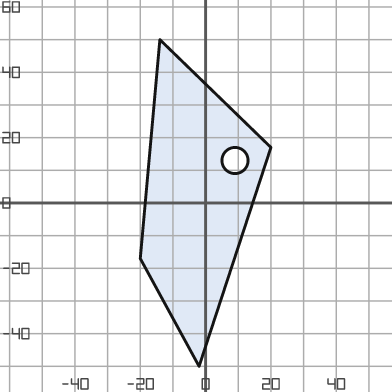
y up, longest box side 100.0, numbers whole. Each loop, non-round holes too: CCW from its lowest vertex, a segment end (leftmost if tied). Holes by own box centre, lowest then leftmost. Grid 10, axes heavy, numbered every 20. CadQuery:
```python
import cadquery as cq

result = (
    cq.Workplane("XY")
    .moveTo(-2.0, -50.0)
    .lineTo(20.0, 17.0)
    .lineTo(-14.0, 50.0)
    .lineTo(-20.0, -17.0)
    .close()
    .moveTo(9.0, 13.0)
    .circle(4.0)
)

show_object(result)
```